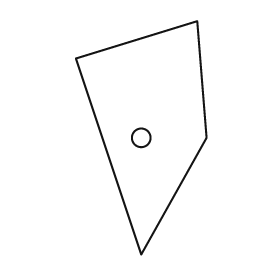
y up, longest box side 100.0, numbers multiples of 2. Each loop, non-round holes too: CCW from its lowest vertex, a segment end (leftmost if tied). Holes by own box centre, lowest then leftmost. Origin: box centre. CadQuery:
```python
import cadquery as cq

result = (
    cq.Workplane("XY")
    .moveTo(0.0, -50.0)
    .lineTo(28.0, 0.0)
    .lineTo(24.0, 50.0)
    .lineTo(-28.0, 34.0)
    .close()
    .moveTo(0.0, 0.0)
    .circle(4.0)
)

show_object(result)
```